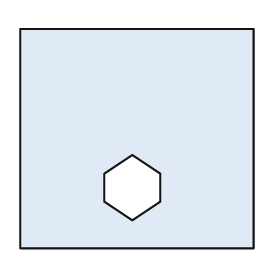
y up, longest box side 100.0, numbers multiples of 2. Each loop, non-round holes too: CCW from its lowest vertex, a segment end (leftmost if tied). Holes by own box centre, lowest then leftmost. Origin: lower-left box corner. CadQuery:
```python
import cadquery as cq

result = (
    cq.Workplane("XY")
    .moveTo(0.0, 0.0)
    .lineTo(100.0, 0.0)
    .lineTo(100.0, 94.0)
    .lineTo(0.0, 94.0)
    .close()
    .moveTo(48.0, 12.0)
    .lineTo(60.0, 20.0)
    .lineTo(60.0, 32.0)
    .lineTo(48.0, 40.0)
    .lineTo(36.0, 32.0)
    .lineTo(36.0, 20.0)
    .close()
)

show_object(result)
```